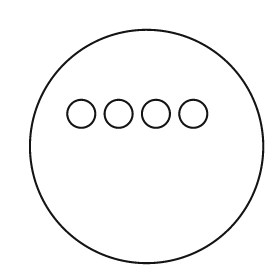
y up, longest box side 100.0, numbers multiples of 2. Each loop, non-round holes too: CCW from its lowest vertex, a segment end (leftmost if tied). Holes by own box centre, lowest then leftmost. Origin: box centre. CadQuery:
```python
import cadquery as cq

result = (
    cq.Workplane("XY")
    .moveTo(0.0, 0.0)
    .circle(50.0)
    .moveTo(-28.0, 14.0)
    .circle(6.0)
    .moveTo(-12.0, 14.0)
    .circle(6.0)
    .moveTo(4.0, 14.0)
    .circle(6.0)
    .moveTo(20.0, 14.0)
    .circle(6.0)
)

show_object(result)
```